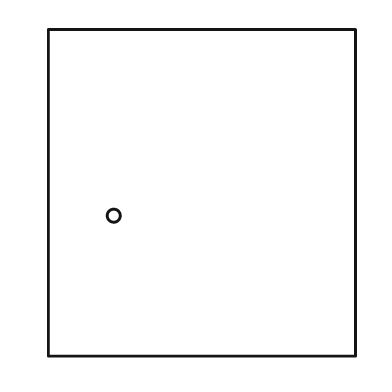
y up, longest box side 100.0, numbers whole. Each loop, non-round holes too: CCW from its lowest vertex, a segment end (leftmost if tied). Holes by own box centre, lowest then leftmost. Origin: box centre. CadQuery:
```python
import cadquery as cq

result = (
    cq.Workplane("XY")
    .moveTo(-47.0, -50.0)
    .lineTo(47.0, -50.0)
    .lineTo(47.0, 50.0)
    .lineTo(-47.0, 50.0)
    .close()
    .moveTo(-27.0, -7.0)
    .circle(2.0)
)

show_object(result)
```